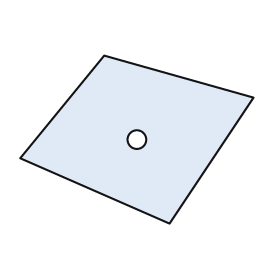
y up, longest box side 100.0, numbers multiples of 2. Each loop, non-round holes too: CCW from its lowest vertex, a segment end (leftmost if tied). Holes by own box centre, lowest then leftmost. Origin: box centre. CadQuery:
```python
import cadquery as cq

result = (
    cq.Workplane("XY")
    .moveTo(14.0, -36.0)
    .lineTo(50.0, 18.0)
    .lineTo(-14.0, 36.0)
    .lineTo(-50.0, -8.0)
    .close()
    .moveTo(0.0, 0.0)
    .circle(4.0)
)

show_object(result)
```